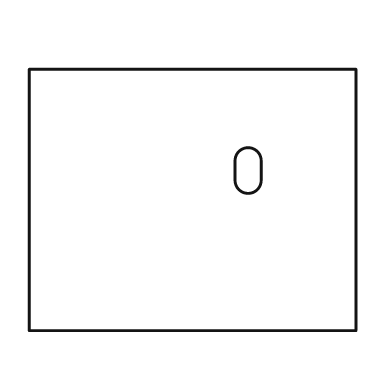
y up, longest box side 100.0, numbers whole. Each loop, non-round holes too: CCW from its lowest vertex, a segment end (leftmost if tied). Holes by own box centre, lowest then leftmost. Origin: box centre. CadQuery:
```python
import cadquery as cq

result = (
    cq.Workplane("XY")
    .moveTo(-50.0, -40.0)
    .lineTo(50.0, -40.0)
    .lineTo(50.0, 40.0)
    .lineTo(-50.0, 40.0)
    .close()
    .moveTo(13.0, 6.0)
    .threePointArc((17.0, 2.0), (21.0, 6.0))
    .lineTo(21.0, 12.0)
    .threePointArc((17.0, 16.0), (13.0, 12.0))
    .close()
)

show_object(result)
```